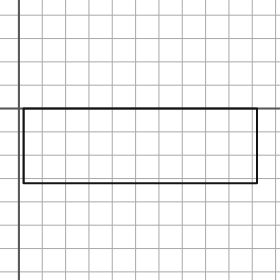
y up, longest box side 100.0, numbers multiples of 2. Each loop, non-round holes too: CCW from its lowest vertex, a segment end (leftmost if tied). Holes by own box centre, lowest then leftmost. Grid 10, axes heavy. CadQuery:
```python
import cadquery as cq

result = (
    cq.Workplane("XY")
    .moveTo(2.0, -32.0)
    .lineTo(102.0, -32.0)
    .lineTo(102.0, 0.0)
    .lineTo(2.0, 0.0)
    .close()
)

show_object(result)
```